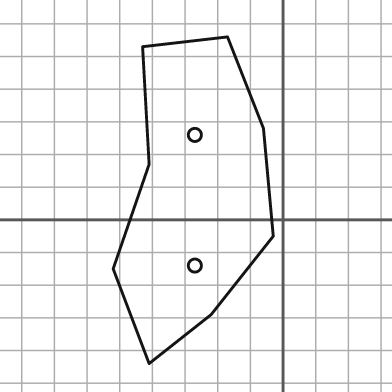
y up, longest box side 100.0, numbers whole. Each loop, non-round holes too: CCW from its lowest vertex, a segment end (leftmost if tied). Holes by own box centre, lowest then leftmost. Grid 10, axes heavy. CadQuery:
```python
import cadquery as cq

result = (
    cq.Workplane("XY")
    .moveTo(-41.0, -44.0)
    .lineTo(-22.0, -29.0)
    .lineTo(-3.0, -5.0)
    .lineTo(-6.0, 28.0)
    .lineTo(-17.0, 56.0)
    .lineTo(-43.0, 53.0)
    .lineTo(-41.0, 17.0)
    .lineTo(-52.0, -15.0)
    .close()
    .moveTo(-27.0, -14.0)
    .circle(2.0)
    .moveTo(-27.0, 26.0)
    .circle(2.0)
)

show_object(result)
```